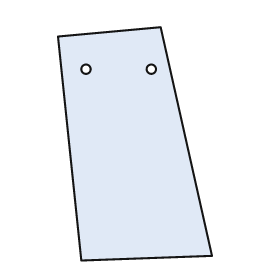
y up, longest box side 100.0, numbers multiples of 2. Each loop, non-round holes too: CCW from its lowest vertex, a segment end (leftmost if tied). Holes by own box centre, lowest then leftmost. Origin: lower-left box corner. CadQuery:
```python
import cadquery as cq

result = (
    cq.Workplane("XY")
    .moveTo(10.0, 0.0)
    .lineTo(66.0, 2.0)
    .lineTo(44.0, 100.0)
    .lineTo(0.0, 96.0)
    .close()
    .moveTo(12.0, 82.0)
    .circle(2.0)
    .moveTo(40.0, 82.0)
    .circle(2.0)
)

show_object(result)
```